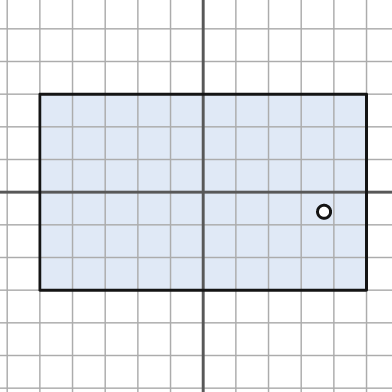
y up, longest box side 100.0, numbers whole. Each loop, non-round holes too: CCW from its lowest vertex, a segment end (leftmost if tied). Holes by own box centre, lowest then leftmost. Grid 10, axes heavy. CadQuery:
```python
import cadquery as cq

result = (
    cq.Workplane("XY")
    .moveTo(-50.0, -30.0)
    .lineTo(50.0, -30.0)
    .lineTo(50.0, 30.0)
    .lineTo(-50.0, 30.0)
    .close()
    .moveTo(37.0, -6.0)
    .circle(2.0)
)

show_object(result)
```